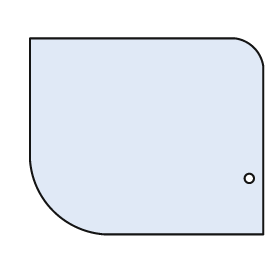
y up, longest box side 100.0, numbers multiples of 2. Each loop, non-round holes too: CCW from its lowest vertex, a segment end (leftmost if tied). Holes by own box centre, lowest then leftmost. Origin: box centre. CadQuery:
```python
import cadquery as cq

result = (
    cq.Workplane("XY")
    .moveTo(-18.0, -42.0)
    .lineTo(50.0, -42.0)
    .lineTo(50.0, 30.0)
    .threePointArc((46.0, 38.0), (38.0, 42.0))
    .lineTo(-50.0, 42.0)
    .lineTo(-50.0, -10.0)
    .threePointArc((-40.0, -32.0), (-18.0, -42.0))
    .close()
    .moveTo(44.0, -18.0)
    .circle(2.0)
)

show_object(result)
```